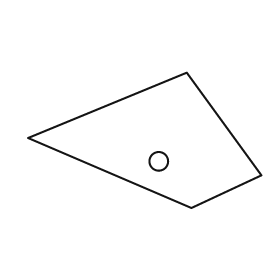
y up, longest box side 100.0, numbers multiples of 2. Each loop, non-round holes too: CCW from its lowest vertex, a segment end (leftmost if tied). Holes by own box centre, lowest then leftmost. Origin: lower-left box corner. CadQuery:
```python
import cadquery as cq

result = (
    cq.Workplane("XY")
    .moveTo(70.0, 0.0)
    .lineTo(100.0, 14.0)
    .lineTo(68.0, 58.0)
    .lineTo(0.0, 30.0)
    .close()
    .moveTo(56.0, 20.0)
    .circle(4.0)
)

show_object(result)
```